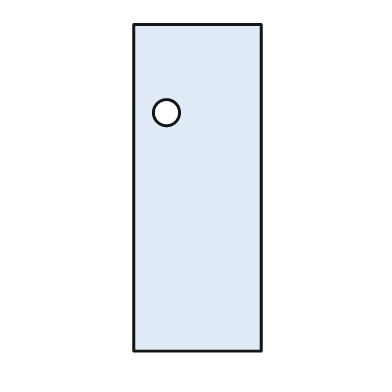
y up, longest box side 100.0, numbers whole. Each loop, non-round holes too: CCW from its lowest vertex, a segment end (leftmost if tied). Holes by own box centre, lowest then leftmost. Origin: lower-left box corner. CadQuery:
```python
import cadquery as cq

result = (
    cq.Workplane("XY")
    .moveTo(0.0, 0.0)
    .lineTo(39.0, 0.0)
    .lineTo(39.0, 100.0)
    .lineTo(0.0, 100.0)
    .close()
    .moveTo(10.0, 73.0)
    .circle(4.0)
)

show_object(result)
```